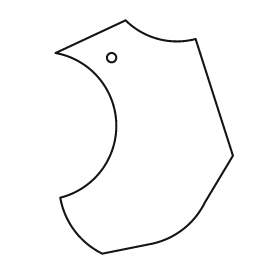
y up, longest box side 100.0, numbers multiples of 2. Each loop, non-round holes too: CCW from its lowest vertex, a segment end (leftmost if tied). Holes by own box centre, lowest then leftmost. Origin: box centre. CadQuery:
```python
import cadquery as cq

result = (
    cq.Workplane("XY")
    .moveTo(-18.0, -50.0)
    .lineTo(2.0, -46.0)
    .threePointArc((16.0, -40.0), (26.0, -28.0))
    .lineTo(38.0, -8.0)
    .lineTo(22.0, 42.0)
    .threePointArc((6.0, 42.0), (-8.0, 50.0))
    .lineTo(-38.0, 36.0)
    .threePointArc((-12.0, 6.0), (-36.0, -26.0))
    .threePointArc((-30.0, -40.0), (-18.0, -50.0))
    .close()
    .moveTo(-14.0, 34.0)
    .circle(2.0)
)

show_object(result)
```